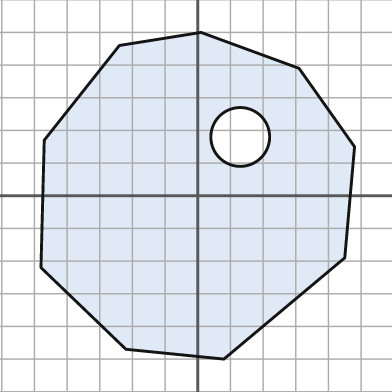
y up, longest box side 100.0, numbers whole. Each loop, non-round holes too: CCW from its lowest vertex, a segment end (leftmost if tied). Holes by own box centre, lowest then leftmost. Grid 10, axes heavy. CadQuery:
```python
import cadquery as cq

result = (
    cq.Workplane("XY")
    .moveTo(8.0, -50.0)
    .lineTo(45.0, -19.0)
    .lineTo(48.0, 15.0)
    .lineTo(31.0, 39.0)
    .lineTo(1.0, 50.0)
    .lineTo(-24.0, 46.0)
    .lineTo(-47.0, 17.0)
    .lineTo(-48.0, -22.0)
    .lineTo(-22.0, -47.0)
    .close()
    .moveTo(13.0, 18.0)
    .circle(9.0)
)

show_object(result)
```